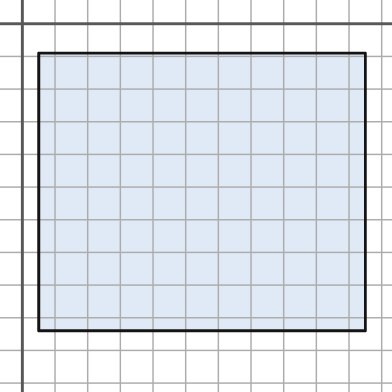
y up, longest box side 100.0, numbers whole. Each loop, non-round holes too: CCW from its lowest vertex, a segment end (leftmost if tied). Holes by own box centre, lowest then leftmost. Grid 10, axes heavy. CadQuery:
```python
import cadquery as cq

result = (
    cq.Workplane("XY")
    .moveTo(5.0, -94.0)
    .lineTo(105.0, -94.0)
    .lineTo(105.0, -9.0)
    .lineTo(5.0, -9.0)
    .close()
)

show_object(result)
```